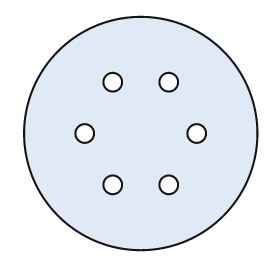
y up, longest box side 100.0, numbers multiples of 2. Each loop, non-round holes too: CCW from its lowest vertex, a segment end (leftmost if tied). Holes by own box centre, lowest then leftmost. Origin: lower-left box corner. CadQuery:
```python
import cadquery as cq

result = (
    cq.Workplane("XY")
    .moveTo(50.0, 50.0)
    .circle(50.0)
    .moveTo(38.0, 28.0)
    .circle(4.0)
    .moveTo(62.0, 28.0)
    .circle(4.0)
    .moveTo(26.0, 50.0)
    .circle(4.0)
    .moveTo(74.0, 50.0)
    .circle(4.0)
    .moveTo(38.0, 72.0)
    .circle(4.0)
    .moveTo(62.0, 72.0)
    .circle(4.0)
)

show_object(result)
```